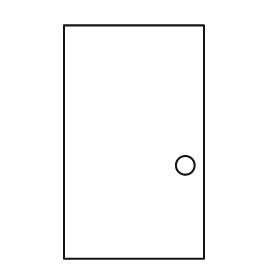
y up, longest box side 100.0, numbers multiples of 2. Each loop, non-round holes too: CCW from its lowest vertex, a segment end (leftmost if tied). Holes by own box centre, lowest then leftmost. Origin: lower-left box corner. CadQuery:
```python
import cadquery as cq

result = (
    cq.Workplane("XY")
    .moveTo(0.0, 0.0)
    .lineTo(60.0, 0.0)
    .lineTo(60.0, 100.0)
    .lineTo(0.0, 100.0)
    .close()
    .moveTo(52.0, 40.0)
    .circle(4.0)
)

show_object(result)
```